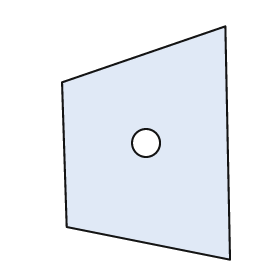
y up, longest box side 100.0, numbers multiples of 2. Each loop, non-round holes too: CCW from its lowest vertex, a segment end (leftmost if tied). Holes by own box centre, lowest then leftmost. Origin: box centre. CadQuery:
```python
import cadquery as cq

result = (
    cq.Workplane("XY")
    .moveTo(36.0, -50.0)
    .lineTo(34.0, 50.0)
    .lineTo(-36.0, 26.0)
    .lineTo(-34.0, -36.0)
    .close()
    .moveTo(0.0, 0.0)
    .circle(6.0)
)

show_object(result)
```